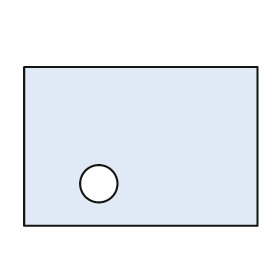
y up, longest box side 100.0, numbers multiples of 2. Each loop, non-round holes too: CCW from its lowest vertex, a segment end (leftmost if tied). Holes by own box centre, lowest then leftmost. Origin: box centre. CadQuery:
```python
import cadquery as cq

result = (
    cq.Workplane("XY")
    .moveTo(-50.0, -34.0)
    .lineTo(50.0, -34.0)
    .lineTo(50.0, 34.0)
    .lineTo(-50.0, 34.0)
    .close()
    .moveTo(-18.0, -16.0)
    .circle(8.0)
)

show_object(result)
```